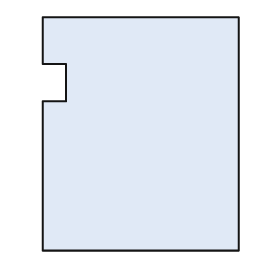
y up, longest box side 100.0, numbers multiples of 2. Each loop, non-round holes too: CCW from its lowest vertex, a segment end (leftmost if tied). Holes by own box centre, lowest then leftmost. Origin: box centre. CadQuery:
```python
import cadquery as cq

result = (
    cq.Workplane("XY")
    .moveTo(-42.0, -50.0)
    .lineTo(42.0, -50.0)
    .lineTo(42.0, 50.0)
    .lineTo(-42.0, 50.0)
    .lineTo(-42.0, 30.0)
    .lineTo(-32.0, 30.0)
    .lineTo(-32.0, 14.0)
    .lineTo(-42.0, 14.0)
    .close()
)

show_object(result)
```